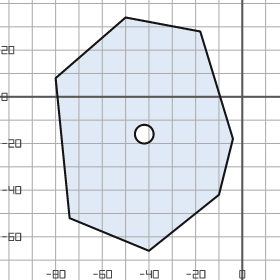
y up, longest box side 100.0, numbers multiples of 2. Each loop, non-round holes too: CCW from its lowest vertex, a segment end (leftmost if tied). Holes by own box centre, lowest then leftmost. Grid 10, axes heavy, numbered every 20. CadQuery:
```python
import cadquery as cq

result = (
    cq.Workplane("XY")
    .moveTo(-40.0, -66.0)
    .lineTo(-10.0, -42.0)
    .lineTo(-4.0, -18.0)
    .lineTo(-18.0, 28.0)
    .lineTo(-50.0, 34.0)
    .lineTo(-80.0, 8.0)
    .lineTo(-74.0, -52.0)
    .close()
    .moveTo(-42.0, -16.0)
    .circle(4.0)
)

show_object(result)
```